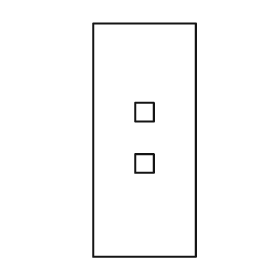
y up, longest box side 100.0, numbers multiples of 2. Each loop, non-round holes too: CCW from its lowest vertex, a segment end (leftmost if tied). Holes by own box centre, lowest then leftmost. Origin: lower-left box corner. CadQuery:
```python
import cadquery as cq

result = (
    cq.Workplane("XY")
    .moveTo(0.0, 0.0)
    .lineTo(44.0, 0.0)
    .lineTo(44.0, 100.0)
    .lineTo(0.0, 100.0)
    .close()
    .moveTo(18.0, 36.0)
    .lineTo(26.0, 36.0)
    .lineTo(26.0, 44.0)
    .lineTo(18.0, 44.0)
    .close()
    .moveTo(18.0, 58.0)
    .lineTo(26.0, 58.0)
    .lineTo(26.0, 66.0)
    .lineTo(18.0, 66.0)
    .close()
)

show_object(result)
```